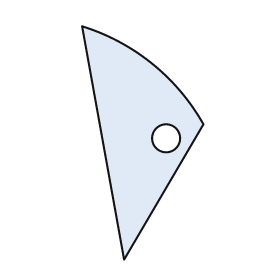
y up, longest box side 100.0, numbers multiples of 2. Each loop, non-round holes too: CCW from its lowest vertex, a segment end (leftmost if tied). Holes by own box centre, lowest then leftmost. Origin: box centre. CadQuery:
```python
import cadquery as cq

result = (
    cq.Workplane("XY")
    .moveTo(-8.0, -50.0)
    .lineTo(26.0, 8.0)
    .threePointArc((4.0, 34.0), (-26.0, 50.0))
    .close()
    .moveTo(10.0, 2.0)
    .circle(6.0)
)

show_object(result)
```